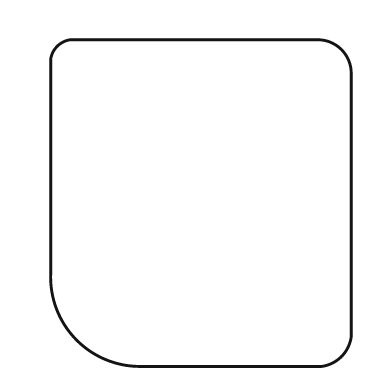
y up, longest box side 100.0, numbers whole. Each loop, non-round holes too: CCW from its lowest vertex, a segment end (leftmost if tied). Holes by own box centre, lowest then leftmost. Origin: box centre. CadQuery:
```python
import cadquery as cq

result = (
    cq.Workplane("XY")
    .moveTo(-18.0, -50.0)
    .lineTo(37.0, -50.0)
    .threePointArc((43.0, -47.0), (46.0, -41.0))
    .lineTo(46.0, 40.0)
    .threePointArc((43.0, 47.0), (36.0, 50.0))
    .lineTo(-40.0, 50.0)
    .threePointArc((-44.0, 48.0), (-46.0, 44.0))
    .lineTo(-46.0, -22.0)
    .threePointArc((-38.0, -42.0), (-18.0, -50.0))
    .close()
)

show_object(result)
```